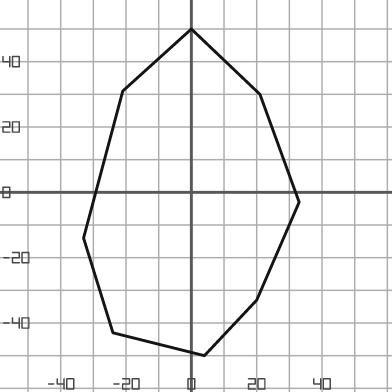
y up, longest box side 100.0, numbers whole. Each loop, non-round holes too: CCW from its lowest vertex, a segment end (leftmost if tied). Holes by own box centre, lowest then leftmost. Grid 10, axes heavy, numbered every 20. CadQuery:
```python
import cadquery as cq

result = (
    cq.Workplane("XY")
    .moveTo(4.0, -50.0)
    .lineTo(20.0, -33.0)
    .lineTo(33.0, -3.0)
    .lineTo(21.0, 30.0)
    .lineTo(0.0, 50.0)
    .lineTo(-21.0, 31.0)
    .lineTo(-33.0, -14.0)
    .lineTo(-24.0, -43.0)
    .close()
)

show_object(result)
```